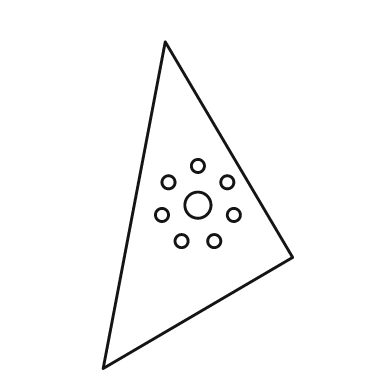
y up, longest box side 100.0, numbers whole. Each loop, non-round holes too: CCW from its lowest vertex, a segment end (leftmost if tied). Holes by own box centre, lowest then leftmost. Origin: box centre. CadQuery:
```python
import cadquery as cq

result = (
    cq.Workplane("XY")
    .moveTo(-29.0, -50.0)
    .lineTo(29.0, -16.0)
    .lineTo(-10.0, 50.0)
    .close()
    .moveTo(-5.0, -11.0)
    .circle(2.0)
    .moveTo(5.0, -11.0)
    .circle(2.0)
    .moveTo(-11.0, -3.0)
    .circle(2.0)
    .moveTo(11.0, -3.0)
    .circle(2.0)
    .moveTo(0.0, 0.0)
    .circle(4.0)
    .moveTo(-9.0, 7.0)
    .circle(2.0)
    .moveTo(9.0, 7.0)
    .circle(2.0)
    .moveTo(0.0, 12.0)
    .circle(2.0)
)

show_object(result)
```